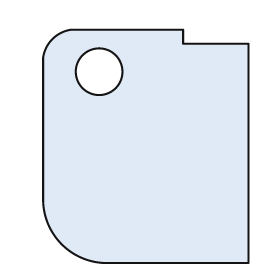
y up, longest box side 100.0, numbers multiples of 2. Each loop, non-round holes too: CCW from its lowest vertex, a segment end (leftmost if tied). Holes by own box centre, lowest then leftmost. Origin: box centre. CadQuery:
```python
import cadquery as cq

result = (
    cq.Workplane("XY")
    .moveTo(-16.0, -50.0)
    .lineTo(44.0, -50.0)
    .lineTo(44.0, 44.0)
    .lineTo(16.0, 44.0)
    .lineTo(16.0, 50.0)
    .lineTo(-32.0, 50.0)
    .threePointArc((-40.0, 46.0), (-44.0, 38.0))
    .lineTo(-44.0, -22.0)
    .threePointArc((-36.0, -42.0), (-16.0, -50.0))
    .close()
    .moveTo(-20.0, 32.0)
    .circle(10.0)
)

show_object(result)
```